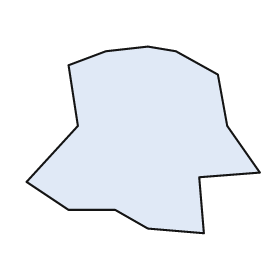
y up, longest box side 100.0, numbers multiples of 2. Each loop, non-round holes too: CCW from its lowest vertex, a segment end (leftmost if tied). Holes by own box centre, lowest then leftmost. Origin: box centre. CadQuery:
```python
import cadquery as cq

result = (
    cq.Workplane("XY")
    .moveTo(26.0, -40.0)
    .lineTo(24.0, -16.0)
    .lineTo(50.0, -14.0)
    .lineTo(36.0, 6.0)
    .lineTo(32.0, 28.0)
    .lineTo(14.0, 38.0)
    .lineTo(2.0, 40.0)
    .lineTo(-16.0, 38.0)
    .lineTo(-32.0, 32.0)
    .lineTo(-28.0, 6.0)
    .lineTo(-50.0, -18.0)
    .lineTo(-32.0, -30.0)
    .lineTo(-12.0, -30.0)
    .lineTo(2.0, -38.0)
    .close()
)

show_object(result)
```